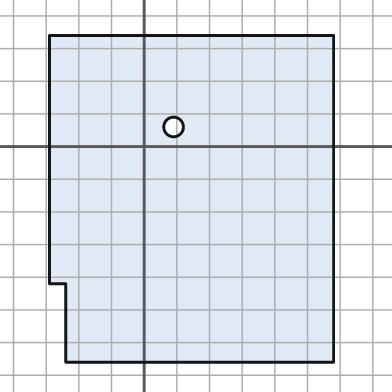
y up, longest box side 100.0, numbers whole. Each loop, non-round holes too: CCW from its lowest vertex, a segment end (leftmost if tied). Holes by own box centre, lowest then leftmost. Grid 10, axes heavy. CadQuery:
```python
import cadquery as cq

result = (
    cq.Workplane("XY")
    .moveTo(-24.0, -66.0)
    .lineTo(58.0, -66.0)
    .lineTo(58.0, 34.0)
    .lineTo(-29.0, 34.0)
    .lineTo(-29.0, -42.0)
    .lineTo(-24.0, -42.0)
    .close()
    .moveTo(9.0, 6.0)
    .circle(3.0)
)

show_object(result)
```